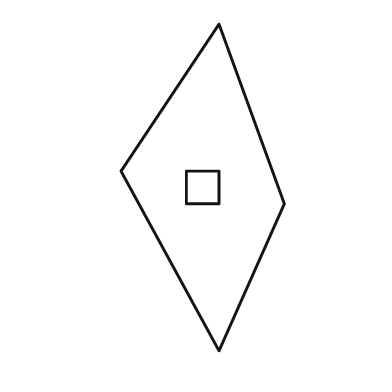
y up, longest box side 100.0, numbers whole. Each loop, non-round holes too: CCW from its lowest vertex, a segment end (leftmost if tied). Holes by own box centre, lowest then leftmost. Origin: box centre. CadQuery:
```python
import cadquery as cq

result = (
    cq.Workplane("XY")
    .moveTo(5.0, -50.0)
    .lineTo(25.0, -5.0)
    .lineTo(5.0, 50.0)
    .lineTo(-25.0, 5.0)
    .close()
    .moveTo(-5.0, -5.0)
    .lineTo(5.0, -5.0)
    .lineTo(5.0, 5.0)
    .lineTo(-5.0, 5.0)
    .close()
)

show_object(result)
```